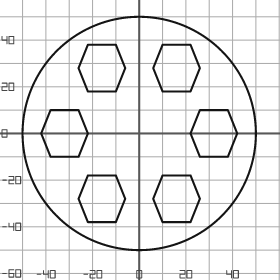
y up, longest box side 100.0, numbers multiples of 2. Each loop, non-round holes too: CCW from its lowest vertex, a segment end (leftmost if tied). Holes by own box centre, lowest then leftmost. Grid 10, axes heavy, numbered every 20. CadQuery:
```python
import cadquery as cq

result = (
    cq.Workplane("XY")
    .moveTo(0.0, 0.0)
    .circle(50.0)
    .moveTo(-22.0, -38.0)
    .lineTo(-10.0, -38.0)
    .lineTo(-6.0, -28.0)
    .lineTo(-10.0, -18.0)
    .lineTo(-22.0, -18.0)
    .lineTo(-26.0, -28.0)
    .close()
    .moveTo(10.0, -38.0)
    .lineTo(22.0, -38.0)
    .lineTo(26.0, -28.0)
    .lineTo(22.0, -18.0)
    .lineTo(10.0, -18.0)
    .lineTo(6.0, -28.0)
    .close()
    .moveTo(-38.0, -10.0)
    .lineTo(-26.0, -10.0)
    .lineTo(-22.0, 0.0)
    .lineTo(-26.0, 10.0)
    .lineTo(-38.0, 10.0)
    .lineTo(-42.0, 0.0)
    .close()
    .moveTo(26.0, -10.0)
    .lineTo(38.0, -10.0)
    .lineTo(42.0, 0.0)
    .lineTo(38.0, 10.0)
    .lineTo(26.0, 10.0)
    .lineTo(22.0, 0.0)
    .close()
    .moveTo(-22.0, 18.0)
    .lineTo(-10.0, 18.0)
    .lineTo(-6.0, 28.0)
    .lineTo(-10.0, 38.0)
    .lineTo(-22.0, 38.0)
    .lineTo(-26.0, 28.0)
    .close()
    .moveTo(10.0, 18.0)
    .lineTo(22.0, 18.0)
    .lineTo(26.0, 28.0)
    .lineTo(22.0, 38.0)
    .lineTo(10.0, 38.0)
    .lineTo(6.0, 28.0)
    .close()
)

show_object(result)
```